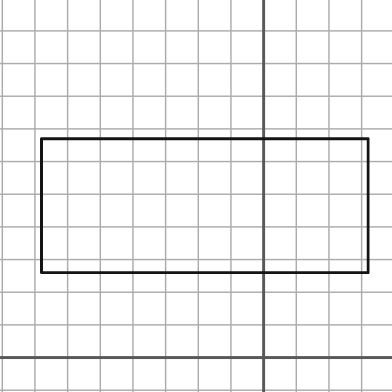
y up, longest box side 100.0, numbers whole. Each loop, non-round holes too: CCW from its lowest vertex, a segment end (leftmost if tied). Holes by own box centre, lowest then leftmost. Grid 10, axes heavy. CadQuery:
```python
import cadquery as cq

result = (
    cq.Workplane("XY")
    .moveTo(-68.0, 26.0)
    .lineTo(32.0, 26.0)
    .lineTo(32.0, 67.0)
    .lineTo(-68.0, 67.0)
    .close()
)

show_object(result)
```